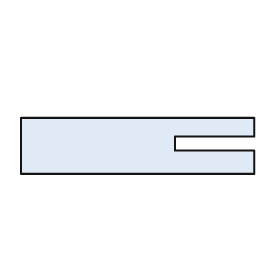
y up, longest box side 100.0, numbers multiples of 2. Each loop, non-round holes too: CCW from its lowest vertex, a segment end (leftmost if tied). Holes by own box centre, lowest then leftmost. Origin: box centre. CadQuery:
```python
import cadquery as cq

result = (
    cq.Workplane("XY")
    .moveTo(-50.0, -12.0)
    .lineTo(50.0, -12.0)
    .lineTo(50.0, -2.0)
    .lineTo(16.0, -2.0)
    .lineTo(16.0, 4.0)
    .lineTo(50.0, 4.0)
    .lineTo(50.0, 12.0)
    .lineTo(-50.0, 12.0)
    .close()
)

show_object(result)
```